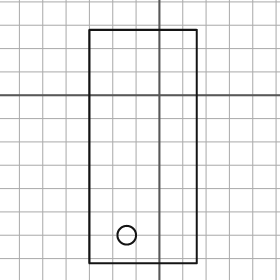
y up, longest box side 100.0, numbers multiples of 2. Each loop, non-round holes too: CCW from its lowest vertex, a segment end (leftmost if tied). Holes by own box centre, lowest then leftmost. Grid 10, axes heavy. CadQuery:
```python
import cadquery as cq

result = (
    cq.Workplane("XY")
    .moveTo(-30.0, -72.0)
    .lineTo(16.0, -72.0)
    .lineTo(16.0, 28.0)
    .lineTo(-30.0, 28.0)
    .close()
    .moveTo(-14.0, -60.0)
    .circle(4.0)
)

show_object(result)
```